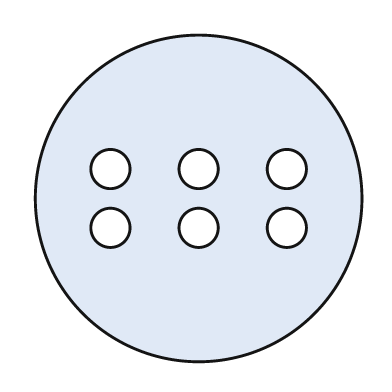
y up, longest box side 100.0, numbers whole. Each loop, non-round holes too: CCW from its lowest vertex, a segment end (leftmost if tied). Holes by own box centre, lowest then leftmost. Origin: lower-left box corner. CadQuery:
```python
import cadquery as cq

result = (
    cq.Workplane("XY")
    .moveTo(50.0, 50.0)
    .circle(50.0)
    .moveTo(23.0, 41.0)
    .circle(6.0)
    .moveTo(50.0, 41.0)
    .circle(6.0)
    .moveTo(77.0, 41.0)
    .circle(6.0)
    .moveTo(23.0, 59.0)
    .circle(6.0)
    .moveTo(50.0, 59.0)
    .circle(6.0)
    .moveTo(77.0, 59.0)
    .circle(6.0)
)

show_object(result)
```